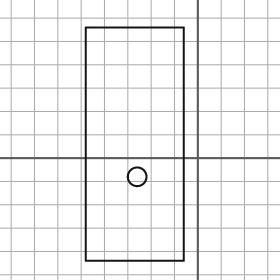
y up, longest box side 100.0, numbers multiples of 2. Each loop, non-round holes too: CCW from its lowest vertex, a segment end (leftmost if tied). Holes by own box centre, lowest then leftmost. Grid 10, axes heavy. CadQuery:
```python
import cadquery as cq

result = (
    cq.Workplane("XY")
    .moveTo(-48.0, -44.0)
    .lineTo(-6.0, -44.0)
    .lineTo(-6.0, 56.0)
    .lineTo(-48.0, 56.0)
    .close()
    .moveTo(-26.0, -8.0)
    .circle(4.0)
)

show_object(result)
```